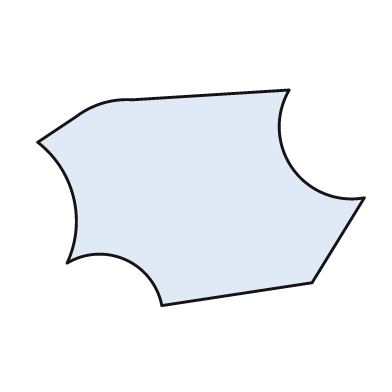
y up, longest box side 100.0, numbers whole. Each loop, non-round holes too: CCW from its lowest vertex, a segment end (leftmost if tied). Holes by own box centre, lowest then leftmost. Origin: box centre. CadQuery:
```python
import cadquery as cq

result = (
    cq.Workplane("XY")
    .moveTo(-12.0, -33.0)
    .lineTo(34.0, -26.0)
    .lineTo(50.0, 0.0)
    .threePointArc((28.0, 9.0), (27.0, 33.0))
    .lineTo(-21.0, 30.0)
    .threePointArc((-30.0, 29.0), (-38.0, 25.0))
    .lineTo(-50.0, 17.0)
    .threePointArc((-39.0, 0.0), (-41.0, -20.0))
    .threePointArc((-23.0, -19.0), (-12.0, -33.0))
    .close()
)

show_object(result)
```